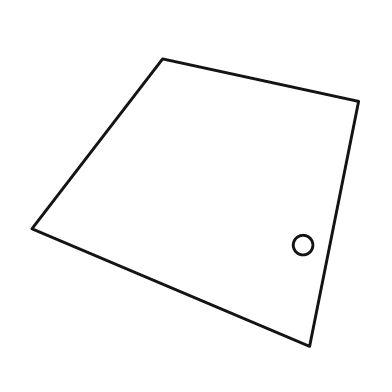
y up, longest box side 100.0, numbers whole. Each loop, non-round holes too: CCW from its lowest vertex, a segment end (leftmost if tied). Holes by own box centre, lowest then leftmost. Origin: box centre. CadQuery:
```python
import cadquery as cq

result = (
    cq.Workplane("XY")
    .moveTo(35.0, -44.0)
    .lineTo(50.0, 31.0)
    .lineTo(-10.0, 44.0)
    .lineTo(-50.0, -8.0)
    .close()
    .moveTo(33.0, -13.0)
    .circle(3.0)
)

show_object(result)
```